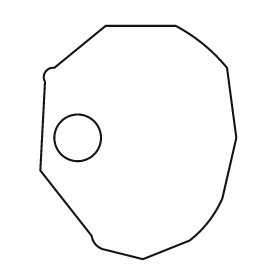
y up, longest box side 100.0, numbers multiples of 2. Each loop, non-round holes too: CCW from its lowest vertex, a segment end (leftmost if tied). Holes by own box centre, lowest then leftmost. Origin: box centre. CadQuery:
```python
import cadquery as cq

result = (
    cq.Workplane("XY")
    .moveTo(2.0, -50.0)
    .lineTo(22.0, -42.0)
    .threePointArc((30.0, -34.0), (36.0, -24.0))
    .lineTo(42.0, 2.0)
    .lineTo(38.0, 32.0)
    .threePointArc((28.0, 42.0), (16.0, 50.0))
    .lineTo(-14.0, 50.0)
    .lineTo(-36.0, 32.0)
    .threePointArc((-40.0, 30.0), (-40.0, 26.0))
    .lineTo(-42.0, -12.0)
    .lineTo(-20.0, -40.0)
    .threePointArc((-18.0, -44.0), (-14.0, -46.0))
    .close()
    .moveTo(-26.0, 2.0)
    .circle(10.0)
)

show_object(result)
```